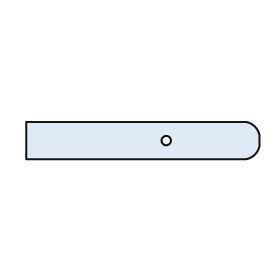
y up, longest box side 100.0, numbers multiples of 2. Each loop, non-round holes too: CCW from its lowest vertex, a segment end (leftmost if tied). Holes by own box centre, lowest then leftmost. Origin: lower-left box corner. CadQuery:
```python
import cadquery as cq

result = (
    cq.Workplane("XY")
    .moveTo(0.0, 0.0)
    .lineTo(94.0, 0.0)
    .threePointArc((98.0, 2.0), (100.0, 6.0))
    .lineTo(100.0, 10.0)
    .threePointArc((98.0, 14.0), (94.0, 16.0))
    .lineTo(0.0, 16.0)
    .close()
    .moveTo(60.0, 8.0)
    .circle(2.0)
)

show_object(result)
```